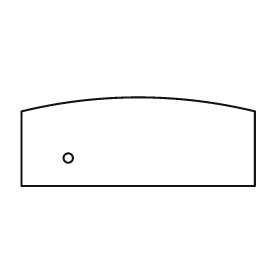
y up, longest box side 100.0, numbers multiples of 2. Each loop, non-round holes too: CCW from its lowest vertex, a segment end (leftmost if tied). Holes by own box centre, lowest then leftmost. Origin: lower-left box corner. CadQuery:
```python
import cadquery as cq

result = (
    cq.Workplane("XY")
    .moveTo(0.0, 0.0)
    .lineTo(100.0, 0.0)
    .lineTo(100.0, 32.0)
    .threePointArc((50.0, 38.0), (0.0, 32.0))
    .close()
    .moveTo(20.0, 12.0)
    .circle(2.0)
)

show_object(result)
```